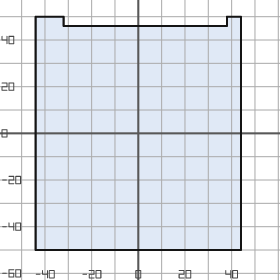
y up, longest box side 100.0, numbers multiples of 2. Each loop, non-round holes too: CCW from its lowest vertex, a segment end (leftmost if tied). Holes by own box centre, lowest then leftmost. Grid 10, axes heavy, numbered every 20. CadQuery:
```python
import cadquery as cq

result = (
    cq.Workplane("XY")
    .moveTo(-44.0, -50.0)
    .lineTo(44.0, -50.0)
    .lineTo(44.0, 50.0)
    .lineTo(38.0, 50.0)
    .lineTo(38.0, 46.0)
    .lineTo(-32.0, 46.0)
    .lineTo(-32.0, 50.0)
    .lineTo(-44.0, 50.0)
    .close()
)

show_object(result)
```